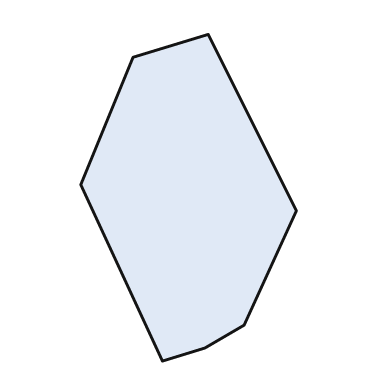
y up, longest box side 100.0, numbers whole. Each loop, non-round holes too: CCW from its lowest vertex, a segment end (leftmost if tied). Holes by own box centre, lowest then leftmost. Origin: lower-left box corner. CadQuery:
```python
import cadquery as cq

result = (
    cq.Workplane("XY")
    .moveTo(25.0, 0.0)
    .lineTo(38.0, 4.0)
    .lineTo(50.0, 11.0)
    .lineTo(66.0, 46.0)
    .lineTo(39.0, 100.0)
    .lineTo(16.0, 93.0)
    .lineTo(0.0, 54.0)
    .close()
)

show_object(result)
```